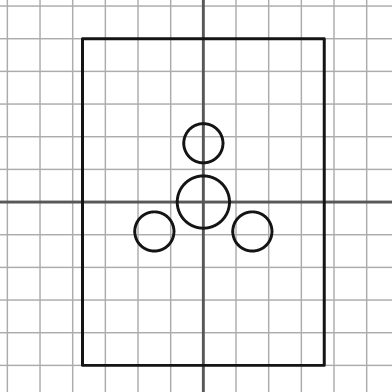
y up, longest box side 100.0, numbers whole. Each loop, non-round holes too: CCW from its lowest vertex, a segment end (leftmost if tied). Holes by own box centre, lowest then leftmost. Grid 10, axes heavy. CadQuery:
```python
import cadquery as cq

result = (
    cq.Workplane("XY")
    .moveTo(-37.0, -50.0)
    .lineTo(37.0, -50.0)
    .lineTo(37.0, 50.0)
    .lineTo(-37.0, 50.0)
    .close()
    .moveTo(-15.0, -9.0)
    .circle(6.0)
    .moveTo(15.0, -9.0)
    .circle(6.0)
    .moveTo(0.0, 0.0)
    .circle(8.0)
    .moveTo(0.0, 18.0)
    .circle(6.0)
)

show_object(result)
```